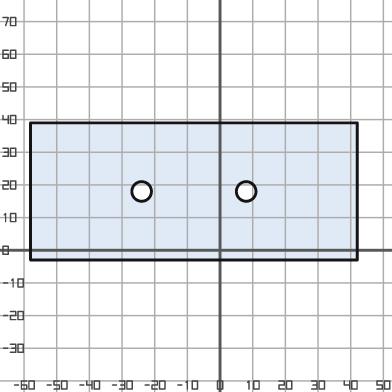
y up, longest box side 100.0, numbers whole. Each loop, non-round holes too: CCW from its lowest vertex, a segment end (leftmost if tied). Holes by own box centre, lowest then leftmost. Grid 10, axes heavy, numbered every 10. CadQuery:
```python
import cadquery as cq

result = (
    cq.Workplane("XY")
    .moveTo(-58.0, -3.0)
    .lineTo(42.0, -3.0)
    .lineTo(42.0, 39.0)
    .lineTo(-58.0, 39.0)
    .close()
    .moveTo(-24.0, 18.0)
    .circle(3.0)
    .moveTo(8.0, 18.0)
    .circle(3.0)
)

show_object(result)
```